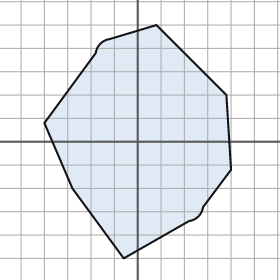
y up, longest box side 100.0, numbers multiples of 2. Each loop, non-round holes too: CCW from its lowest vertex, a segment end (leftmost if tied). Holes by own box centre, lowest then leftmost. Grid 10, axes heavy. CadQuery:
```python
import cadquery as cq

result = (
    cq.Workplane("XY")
    .moveTo(-6.0, -50.0)
    .lineTo(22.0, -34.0)
    .threePointArc((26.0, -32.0), (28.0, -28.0))
    .lineTo(40.0, -12.0)
    .lineTo(38.0, 20.0)
    .lineTo(8.0, 50.0)
    .lineTo(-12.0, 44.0)
    .threePointArc((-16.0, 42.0), (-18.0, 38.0))
    .lineTo(-40.0, 8.0)
    .lineTo(-28.0, -20.0)
    .close()
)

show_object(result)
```